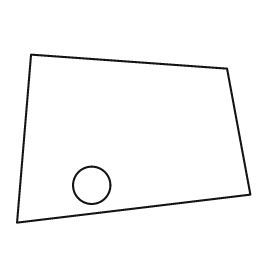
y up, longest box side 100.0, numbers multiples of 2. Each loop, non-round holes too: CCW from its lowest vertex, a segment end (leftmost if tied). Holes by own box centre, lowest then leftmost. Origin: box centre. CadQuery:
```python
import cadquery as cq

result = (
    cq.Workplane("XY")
    .moveTo(-50.0, -36.0)
    .lineTo(50.0, -24.0)
    .lineTo(40.0, 30.0)
    .lineTo(-44.0, 36.0)
    .close()
    .moveTo(-18.0, -20.0)
    .circle(8.0)
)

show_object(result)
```